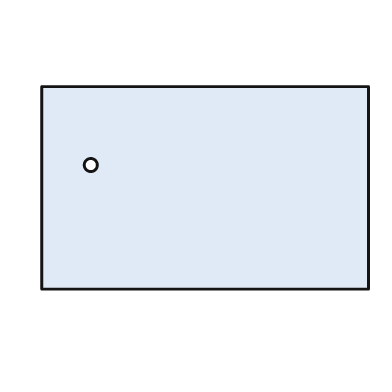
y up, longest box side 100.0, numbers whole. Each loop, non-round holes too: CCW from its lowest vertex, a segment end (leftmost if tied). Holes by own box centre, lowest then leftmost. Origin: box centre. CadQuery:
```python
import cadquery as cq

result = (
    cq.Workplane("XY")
    .moveTo(-50.0, -31.0)
    .lineTo(50.0, -31.0)
    .lineTo(50.0, 31.0)
    .lineTo(-50.0, 31.0)
    .close()
    .moveTo(-35.0, 7.0)
    .circle(2.0)
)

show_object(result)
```